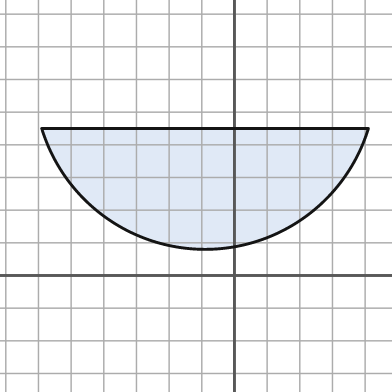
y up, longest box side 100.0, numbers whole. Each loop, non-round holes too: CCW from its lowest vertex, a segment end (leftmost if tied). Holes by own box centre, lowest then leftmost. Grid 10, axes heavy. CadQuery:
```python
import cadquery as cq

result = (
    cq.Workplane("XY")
    .moveTo(-59.0, 45.0)
    .threePointArc((-9.0, 8.0), (41.0, 45.0))
    .close()
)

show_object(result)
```